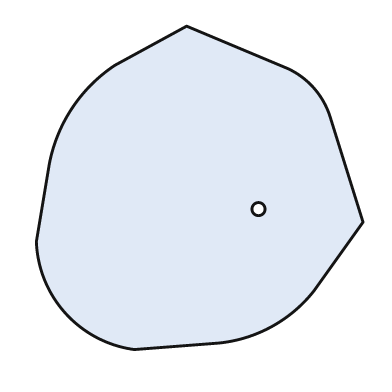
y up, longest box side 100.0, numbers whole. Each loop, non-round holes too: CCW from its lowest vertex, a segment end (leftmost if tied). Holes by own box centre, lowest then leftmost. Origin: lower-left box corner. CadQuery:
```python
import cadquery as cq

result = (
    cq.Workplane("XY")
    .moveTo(30.0, 0.0)
    .lineTo(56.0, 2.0)
    .threePointArc((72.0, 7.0), (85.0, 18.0))
    .lineTo(100.0, 39.0)
    .lineTo(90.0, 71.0)
    .threePointArc((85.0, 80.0), (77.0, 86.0))
    .lineTo(46.0, 99.0)
    .lineTo(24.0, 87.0)
    .threePointArc((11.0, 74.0), (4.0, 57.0))
    .lineTo(0.0, 33.0)
    .threePointArc((9.0, 11.0), (30.0, 0.0))
    .close()
    .moveTo(68.0, 43.0)
    .circle(2.0)
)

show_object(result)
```